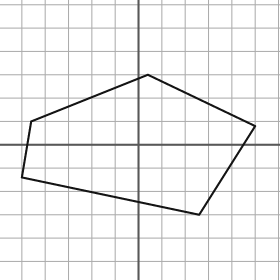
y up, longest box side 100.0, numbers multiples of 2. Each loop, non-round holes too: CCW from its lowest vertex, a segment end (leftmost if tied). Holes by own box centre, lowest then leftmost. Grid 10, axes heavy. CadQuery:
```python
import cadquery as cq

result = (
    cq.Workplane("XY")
    .moveTo(26.0, -30.0)
    .lineTo(50.0, 8.0)
    .lineTo(4.0, 30.0)
    .lineTo(-46.0, 10.0)
    .lineTo(-50.0, -14.0)
    .close()
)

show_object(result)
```